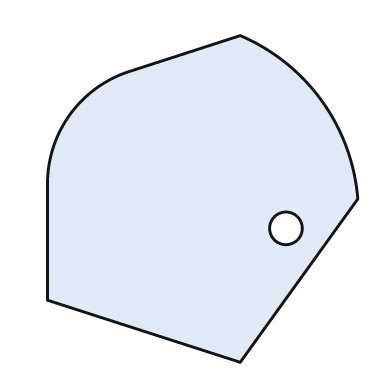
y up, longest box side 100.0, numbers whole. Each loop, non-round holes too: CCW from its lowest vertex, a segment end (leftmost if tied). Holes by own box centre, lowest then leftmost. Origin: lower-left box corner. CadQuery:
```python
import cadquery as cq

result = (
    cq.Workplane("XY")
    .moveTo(59.0, 0.0)
    .lineTo(95.0, 50.0)
    .threePointArc((84.0, 80.0), (59.0, 100.0))
    .lineTo(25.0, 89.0)
    .threePointArc((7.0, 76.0), (0.0, 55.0))
    .lineTo(0.0, 19.0)
    .close()
    .moveTo(73.0, 41.0)
    .circle(5.0)
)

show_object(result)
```